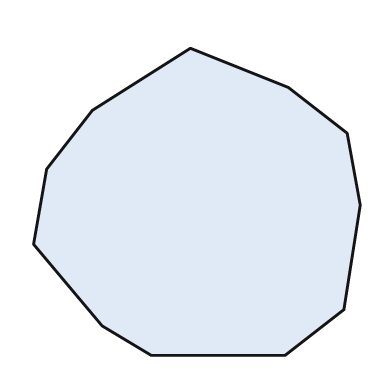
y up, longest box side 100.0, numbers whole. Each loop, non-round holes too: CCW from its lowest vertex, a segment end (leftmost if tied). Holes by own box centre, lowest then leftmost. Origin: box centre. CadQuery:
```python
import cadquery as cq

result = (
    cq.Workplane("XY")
    .moveTo(-14.0, -47.0)
    .lineTo(27.0, -47.0)
    .lineTo(45.0, -33.0)
    .lineTo(50.0, -1.0)
    .lineTo(46.0, 21.0)
    .lineTo(28.0, 35.0)
    .lineTo(-2.0, 47.0)
    .lineTo(-32.0, 28.0)
    .lineTo(-46.0, 10.0)
    .lineTo(-50.0, -13.0)
    .lineTo(-29.0, -38.0)
    .close()
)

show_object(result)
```